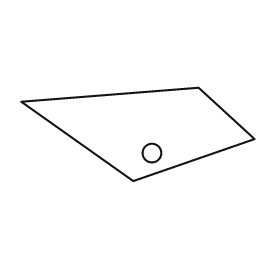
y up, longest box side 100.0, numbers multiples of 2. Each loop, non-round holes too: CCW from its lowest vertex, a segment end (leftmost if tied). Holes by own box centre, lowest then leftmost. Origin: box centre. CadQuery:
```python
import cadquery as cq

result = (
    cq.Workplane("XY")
    .moveTo(-2.0, -20.0)
    .lineTo(50.0, -2.0)
    .lineTo(26.0, 20.0)
    .lineTo(-50.0, 14.0)
    .close()
    .moveTo(6.0, -8.0)
    .circle(4.0)
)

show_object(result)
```